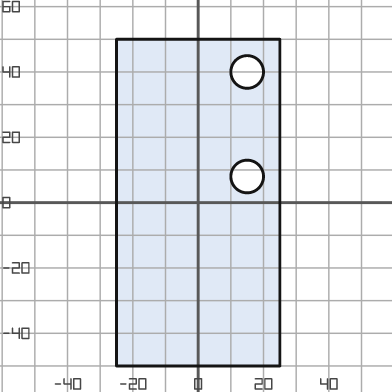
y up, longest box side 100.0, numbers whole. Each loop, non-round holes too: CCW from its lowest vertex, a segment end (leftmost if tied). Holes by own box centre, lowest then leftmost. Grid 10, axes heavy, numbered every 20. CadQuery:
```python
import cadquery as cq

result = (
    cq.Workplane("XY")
    .moveTo(-25.0, -50.0)
    .lineTo(25.0, -50.0)
    .lineTo(25.0, 50.0)
    .lineTo(-25.0, 50.0)
    .close()
    .moveTo(15.0, 8.0)
    .circle(5.0)
    .moveTo(15.0, 40.0)
    .circle(5.0)
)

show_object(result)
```